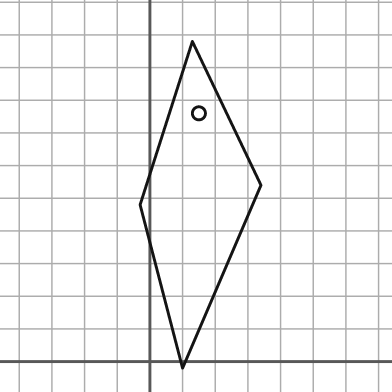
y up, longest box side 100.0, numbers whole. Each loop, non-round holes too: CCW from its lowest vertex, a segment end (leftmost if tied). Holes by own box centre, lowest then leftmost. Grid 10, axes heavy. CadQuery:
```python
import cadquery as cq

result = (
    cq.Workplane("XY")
    .moveTo(10.0, -2.0)
    .lineTo(34.0, 54.0)
    .lineTo(13.0, 98.0)
    .lineTo(-3.0, 48.0)
    .close()
    .moveTo(15.0, 76.0)
    .circle(2.0)
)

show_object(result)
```